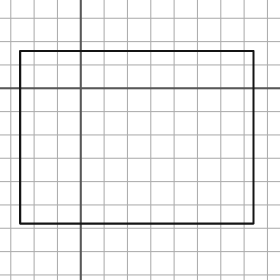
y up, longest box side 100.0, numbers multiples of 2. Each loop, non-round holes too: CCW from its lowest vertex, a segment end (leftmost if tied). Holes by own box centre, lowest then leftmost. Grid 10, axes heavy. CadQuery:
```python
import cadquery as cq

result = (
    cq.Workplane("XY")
    .moveTo(-26.0, -58.0)
    .lineTo(74.0, -58.0)
    .lineTo(74.0, 16.0)
    .lineTo(-26.0, 16.0)
    .close()
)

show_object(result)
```